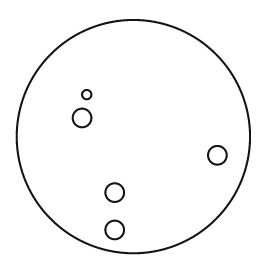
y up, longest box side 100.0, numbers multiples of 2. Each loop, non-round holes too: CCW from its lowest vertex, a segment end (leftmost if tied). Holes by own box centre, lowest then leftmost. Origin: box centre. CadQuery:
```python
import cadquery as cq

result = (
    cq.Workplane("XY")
    .moveTo(0.0, 0.0)
    .circle(50.0)
    .moveTo(-8.0, -40.0)
    .circle(4.0)
    .moveTo(-8.0, -24.0)
    .circle(4.0)
    .moveTo(36.0, -8.0)
    .circle(4.0)
    .moveTo(-22.0, 8.0)
    .circle(4.0)
    .moveTo(-20.0, 18.0)
    .circle(2.0)
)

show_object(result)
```